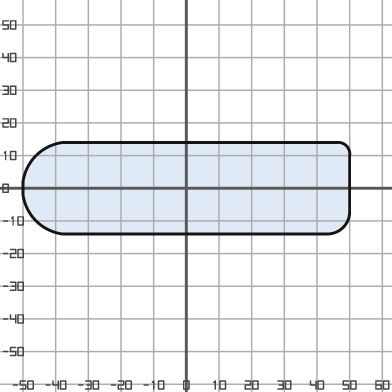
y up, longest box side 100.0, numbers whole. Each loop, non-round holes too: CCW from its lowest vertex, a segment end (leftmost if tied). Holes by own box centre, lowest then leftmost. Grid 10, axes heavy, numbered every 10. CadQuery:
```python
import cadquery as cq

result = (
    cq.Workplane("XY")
    .moveTo(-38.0, -14.0)
    .lineTo(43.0, -14.0)
    .threePointArc((48.0, -12.0), (50.0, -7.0))
    .lineTo(50.0, 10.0)
    .threePointArc((49.0, 13.0), (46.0, 14.0))
    .lineTo(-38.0, 14.0)
    .threePointArc((-46.0, 10.0), (-50.0, 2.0))
    .lineTo(-50.0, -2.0)
    .threePointArc((-46.0, -10.0), (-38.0, -14.0))
    .close()
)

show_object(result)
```